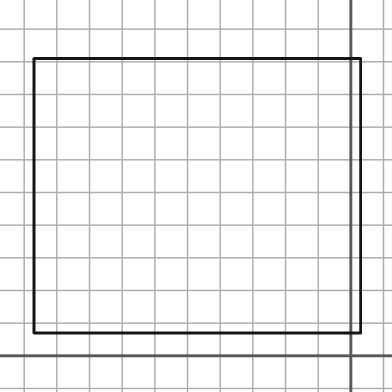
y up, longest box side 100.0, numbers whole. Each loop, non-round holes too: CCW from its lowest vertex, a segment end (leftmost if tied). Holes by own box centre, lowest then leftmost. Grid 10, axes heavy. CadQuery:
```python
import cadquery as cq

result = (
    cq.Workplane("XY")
    .moveTo(-97.0, 7.0)
    .lineTo(3.0, 7.0)
    .lineTo(3.0, 91.0)
    .lineTo(-97.0, 91.0)
    .close()
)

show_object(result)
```